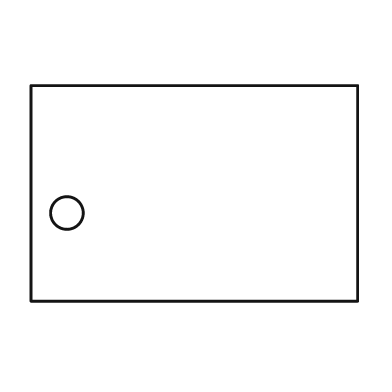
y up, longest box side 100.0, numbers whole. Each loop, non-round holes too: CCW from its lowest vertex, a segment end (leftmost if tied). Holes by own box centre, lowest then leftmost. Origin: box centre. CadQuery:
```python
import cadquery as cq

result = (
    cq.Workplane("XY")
    .moveTo(-50.0, -33.0)
    .lineTo(50.0, -33.0)
    .lineTo(50.0, 33.0)
    .lineTo(-50.0, 33.0)
    .close()
    .moveTo(-39.0, -6.0)
    .circle(5.0)
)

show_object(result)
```